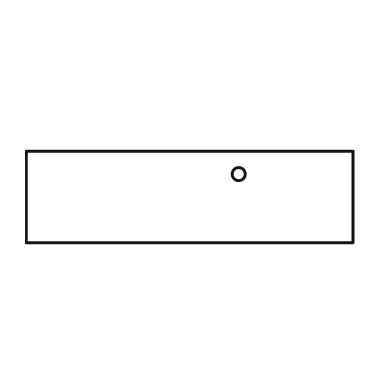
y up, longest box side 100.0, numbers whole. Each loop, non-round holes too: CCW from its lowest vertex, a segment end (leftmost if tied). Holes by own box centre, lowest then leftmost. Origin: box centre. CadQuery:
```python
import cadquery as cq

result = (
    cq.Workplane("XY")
    .moveTo(-50.0, -14.0)
    .lineTo(50.0, -14.0)
    .lineTo(50.0, 14.0)
    .lineTo(-50.0, 14.0)
    .close()
    .moveTo(15.0, 7.0)
    .circle(2.0)
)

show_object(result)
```